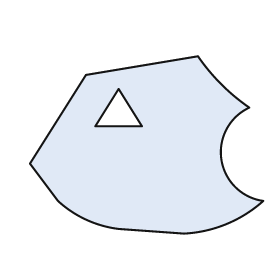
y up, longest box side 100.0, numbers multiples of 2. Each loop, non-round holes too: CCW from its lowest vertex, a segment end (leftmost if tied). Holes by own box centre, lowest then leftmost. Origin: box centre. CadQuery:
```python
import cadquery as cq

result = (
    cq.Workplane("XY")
    .moveTo(16.0, -38.0)
    .threePointArc((34.0, -34.0), (50.0, -24.0))
    .threePointArc((32.0, -6.0), (44.0, 16.0))
    .threePointArc((32.0, 26.0), (22.0, 38.0))
    .lineTo(-26.0, 30.0)
    .lineTo(-50.0, -8.0)
    .lineTo(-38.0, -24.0)
    .threePointArc((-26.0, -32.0), (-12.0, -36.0))
    .close()
    .moveTo(-22.0, 8.0)
    .lineTo(-2.0, 8.0)
    .lineTo(-12.0, 24.0)
    .close()
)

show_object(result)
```